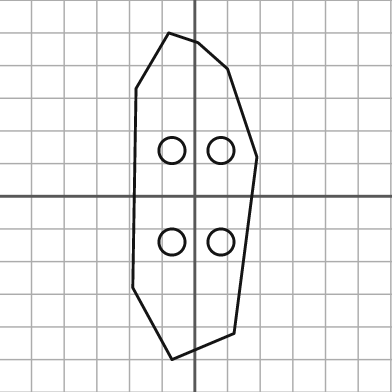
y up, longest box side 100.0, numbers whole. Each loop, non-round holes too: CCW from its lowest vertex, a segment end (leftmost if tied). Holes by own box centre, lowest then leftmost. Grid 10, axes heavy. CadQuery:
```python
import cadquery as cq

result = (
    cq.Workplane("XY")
    .moveTo(-7.0, -50.0)
    .lineTo(12.0, -42.0)
    .lineTo(19.0, 12.0)
    .lineTo(10.0, 39.0)
    .lineTo(1.0, 47.0)
    .lineTo(-8.0, 50.0)
    .lineTo(-18.0, 33.0)
    .lineTo(-19.0, -28.0)
    .close()
    .moveTo(-7.0, -14.0)
    .circle(4.0)
    .moveTo(8.0, -14.0)
    .circle(4.0)
    .moveTo(-7.0, 14.0)
    .circle(4.0)
    .moveTo(8.0, 14.0)
    .circle(4.0)
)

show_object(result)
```